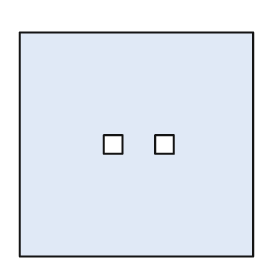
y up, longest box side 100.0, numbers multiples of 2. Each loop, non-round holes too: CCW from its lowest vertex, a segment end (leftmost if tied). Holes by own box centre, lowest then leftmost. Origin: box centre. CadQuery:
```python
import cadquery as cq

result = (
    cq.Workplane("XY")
    .moveTo(-50.0, -48.0)
    .lineTo(50.0, -48.0)
    .lineTo(50.0, 48.0)
    .lineTo(-50.0, 48.0)
    .close()
    .moveTo(-14.0, -4.0)
    .lineTo(-6.0, -4.0)
    .lineTo(-6.0, 4.0)
    .lineTo(-14.0, 4.0)
    .close()
    .moveTo(8.0, -4.0)
    .lineTo(16.0, -4.0)
    .lineTo(16.0, 4.0)
    .lineTo(8.0, 4.0)
    .close()
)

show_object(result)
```